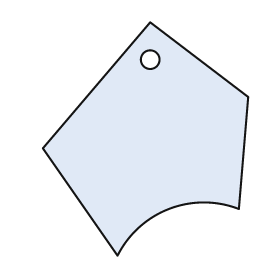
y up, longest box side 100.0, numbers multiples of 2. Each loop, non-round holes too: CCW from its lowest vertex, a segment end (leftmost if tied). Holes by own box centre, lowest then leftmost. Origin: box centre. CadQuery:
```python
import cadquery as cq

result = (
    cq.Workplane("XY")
    .moveTo(-12.0, -50.0)
    .threePointArc((10.0, -30.0), (40.0, -30.0))
    .lineTo(44.0, 18.0)
    .lineTo(2.0, 50.0)
    .lineTo(-44.0, -4.0)
    .close()
    .moveTo(2.0, 34.0)
    .circle(4.0)
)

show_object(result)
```